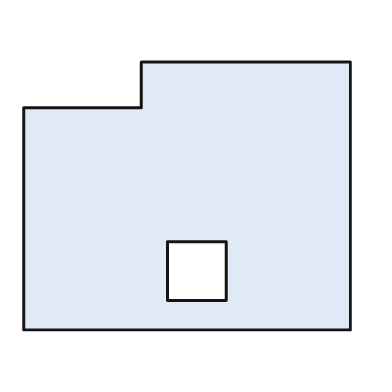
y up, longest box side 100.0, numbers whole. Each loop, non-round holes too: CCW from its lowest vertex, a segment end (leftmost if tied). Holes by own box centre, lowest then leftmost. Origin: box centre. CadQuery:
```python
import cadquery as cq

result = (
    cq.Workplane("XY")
    .moveTo(-50.0, -41.0)
    .lineTo(50.0, -41.0)
    .lineTo(50.0, 41.0)
    .lineTo(-14.0, 41.0)
    .lineTo(-14.0, 27.0)
    .lineTo(-50.0, 27.0)
    .close()
    .moveTo(-6.0, -32.0)
    .lineTo(12.0, -32.0)
    .lineTo(12.0, -14.0)
    .lineTo(-6.0, -14.0)
    .close()
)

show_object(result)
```